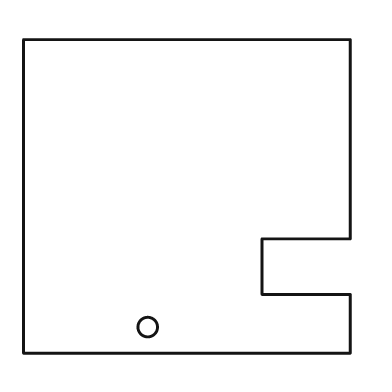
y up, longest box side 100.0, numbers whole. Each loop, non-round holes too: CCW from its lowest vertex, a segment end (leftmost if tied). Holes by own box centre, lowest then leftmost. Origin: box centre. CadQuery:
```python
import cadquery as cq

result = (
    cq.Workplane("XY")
    .moveTo(-50.0, -48.0)
    .lineTo(50.0, -48.0)
    .lineTo(50.0, -30.0)
    .lineTo(23.0, -30.0)
    .lineTo(23.0, -13.0)
    .lineTo(50.0, -13.0)
    .lineTo(50.0, 48.0)
    .lineTo(-50.0, 48.0)
    .close()
    .moveTo(-12.0, -40.0)
    .circle(3.0)
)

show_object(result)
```